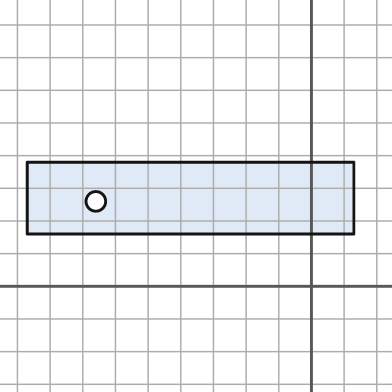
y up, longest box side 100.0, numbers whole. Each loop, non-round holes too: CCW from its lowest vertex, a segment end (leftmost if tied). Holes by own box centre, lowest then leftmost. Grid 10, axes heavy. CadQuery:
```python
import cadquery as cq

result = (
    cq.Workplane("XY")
    .moveTo(-87.0, 16.0)
    .lineTo(13.0, 16.0)
    .lineTo(13.0, 38.0)
    .lineTo(-87.0, 38.0)
    .close()
    .moveTo(-66.0, 26.0)
    .circle(3.0)
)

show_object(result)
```